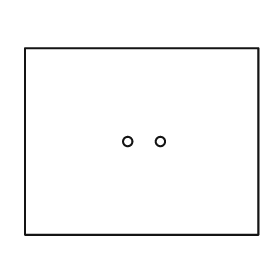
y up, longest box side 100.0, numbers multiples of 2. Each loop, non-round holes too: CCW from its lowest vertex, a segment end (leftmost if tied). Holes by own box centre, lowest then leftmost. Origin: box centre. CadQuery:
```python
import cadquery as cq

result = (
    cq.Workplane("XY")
    .moveTo(-50.0, -40.0)
    .lineTo(50.0, -40.0)
    .lineTo(50.0, 40.0)
    .lineTo(-50.0, 40.0)
    .close()
    .moveTo(-6.0, 0.0)
    .circle(2.0)
    .moveTo(8.0, 0.0)
    .circle(2.0)
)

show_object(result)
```